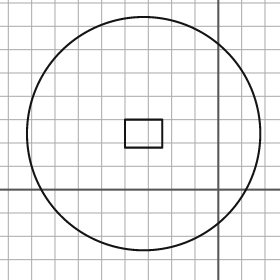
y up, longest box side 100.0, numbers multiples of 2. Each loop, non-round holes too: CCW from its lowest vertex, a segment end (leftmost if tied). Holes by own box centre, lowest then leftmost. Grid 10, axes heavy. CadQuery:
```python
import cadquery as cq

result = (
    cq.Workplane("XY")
    .moveTo(-32.0, 24.0)
    .circle(50.0)
    .moveTo(-40.0, 18.0)
    .lineTo(-24.0, 18.0)
    .lineTo(-24.0, 30.0)
    .lineTo(-40.0, 30.0)
    .close()
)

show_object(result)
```